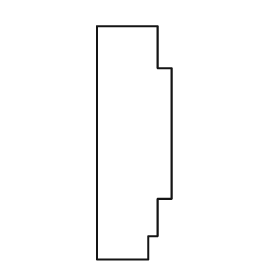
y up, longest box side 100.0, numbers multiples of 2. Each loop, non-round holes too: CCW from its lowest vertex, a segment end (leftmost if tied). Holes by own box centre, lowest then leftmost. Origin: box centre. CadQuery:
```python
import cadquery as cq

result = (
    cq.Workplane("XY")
    .moveTo(-16.0, -50.0)
    .lineTo(6.0, -50.0)
    .lineTo(6.0, -40.0)
    .lineTo(10.0, -40.0)
    .lineTo(10.0, -24.0)
    .lineTo(16.0, -24.0)
    .lineTo(16.0, 32.0)
    .lineTo(10.0, 32.0)
    .lineTo(10.0, 50.0)
    .lineTo(-16.0, 50.0)
    .close()
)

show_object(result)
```